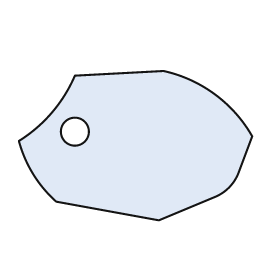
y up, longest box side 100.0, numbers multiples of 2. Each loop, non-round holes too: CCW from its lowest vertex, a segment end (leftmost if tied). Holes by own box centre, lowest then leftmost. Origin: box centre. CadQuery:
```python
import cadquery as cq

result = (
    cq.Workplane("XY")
    .moveTo(10.0, -32.0)
    .lineTo(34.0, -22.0)
    .threePointArc((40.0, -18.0), (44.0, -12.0))
    .lineTo(50.0, 4.0)
    .threePointArc((34.0, 22.0), (12.0, 32.0))
    .lineTo(-26.0, 30.0)
    .threePointArc((-36.0, 14.0), (-50.0, 2.0))
    .threePointArc((-44.0, -12.0), (-34.0, -24.0))
    .close()
    .moveTo(-26.0, 6.0)
    .circle(6.0)
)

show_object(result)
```